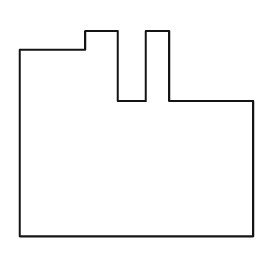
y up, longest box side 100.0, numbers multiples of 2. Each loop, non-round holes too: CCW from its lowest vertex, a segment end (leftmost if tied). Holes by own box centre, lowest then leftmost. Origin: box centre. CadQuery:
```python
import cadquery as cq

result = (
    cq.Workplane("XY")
    .moveTo(-50.0, -44.0)
    .lineTo(50.0, -44.0)
    .lineTo(50.0, 14.0)
    .lineTo(14.0, 14.0)
    .lineTo(14.0, 44.0)
    .lineTo(4.0, 44.0)
    .lineTo(4.0, 14.0)
    .lineTo(-8.0, 14.0)
    .lineTo(-8.0, 44.0)
    .lineTo(-22.0, 44.0)
    .lineTo(-22.0, 36.0)
    .lineTo(-50.0, 36.0)
    .close()
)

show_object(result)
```